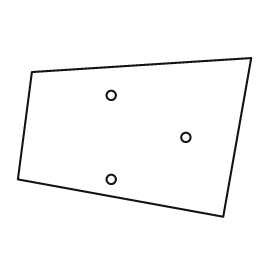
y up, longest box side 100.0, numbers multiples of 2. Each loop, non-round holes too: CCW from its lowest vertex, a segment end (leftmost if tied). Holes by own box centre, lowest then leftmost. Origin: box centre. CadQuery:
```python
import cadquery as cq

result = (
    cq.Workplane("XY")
    .moveTo(38.0, -34.0)
    .lineTo(50.0, 34.0)
    .lineTo(-44.0, 28.0)
    .lineTo(-50.0, -18.0)
    .close()
    .moveTo(-10.0, -18.0)
    .circle(2.0)
    .moveTo(22.0, 0.0)
    .circle(2.0)
    .moveTo(-10.0, 18.0)
    .circle(2.0)
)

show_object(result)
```